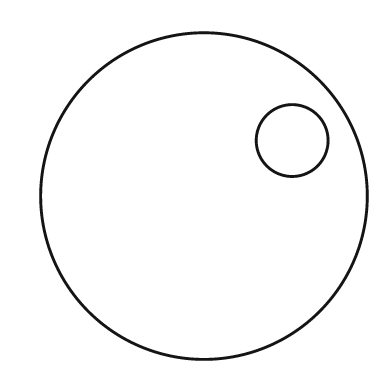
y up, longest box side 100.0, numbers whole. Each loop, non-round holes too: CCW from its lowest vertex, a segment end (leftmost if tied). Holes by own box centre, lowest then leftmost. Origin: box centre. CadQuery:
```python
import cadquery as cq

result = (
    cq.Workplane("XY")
    .moveTo(0.0, 0.0)
    .circle(50.0)
    .moveTo(27.0, 17.0)
    .circle(11.0)
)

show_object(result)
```